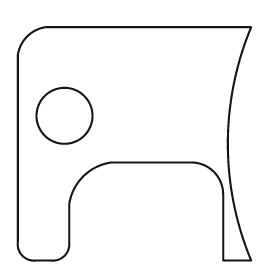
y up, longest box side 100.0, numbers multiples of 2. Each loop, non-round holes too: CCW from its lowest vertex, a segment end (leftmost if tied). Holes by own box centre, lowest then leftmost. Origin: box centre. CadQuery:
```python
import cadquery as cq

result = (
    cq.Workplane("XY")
    .moveTo(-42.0, -50.0)
    .lineTo(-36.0, -50.0)
    .threePointArc((-30.0, -48.0), (-28.0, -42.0))
    .lineTo(-28.0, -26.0)
    .threePointArc((-22.0, -14.0), (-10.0, -8.0))
    .lineTo(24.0, -8.0)
    .threePointArc((34.0, -12.0), (38.0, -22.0))
    .lineTo(38.0, -50.0)
    .lineTo(50.0, -50.0)
    .threePointArc((40.0, 0.0), (50.0, 50.0))
    .lineTo(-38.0, 50.0)
    .threePointArc((-46.0, 46.0), (-50.0, 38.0))
    .lineTo(-50.0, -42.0)
    .threePointArc((-48.0, -48.0), (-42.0, -50.0))
    .close()
    .moveTo(-30.0, 12.0)
    .circle(12.0)
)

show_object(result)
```